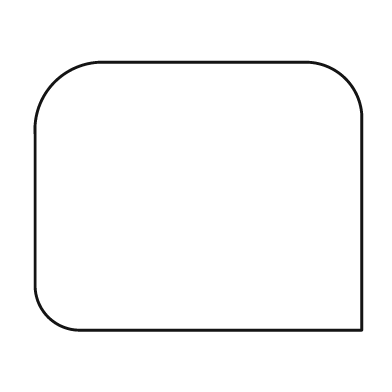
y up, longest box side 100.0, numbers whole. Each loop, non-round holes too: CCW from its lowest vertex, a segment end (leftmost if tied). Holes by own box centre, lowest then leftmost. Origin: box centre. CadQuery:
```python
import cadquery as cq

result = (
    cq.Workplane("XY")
    .moveTo(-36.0, -41.0)
    .lineTo(50.0, -41.0)
    .lineTo(50.0, 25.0)
    .threePointArc((45.0, 36.0), (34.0, 41.0))
    .lineTo(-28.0, 41.0)
    .threePointArc((-44.0, 35.0), (-50.0, 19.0))
    .lineTo(-50.0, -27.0)
    .threePointArc((-46.0, -37.0), (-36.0, -41.0))
    .close()
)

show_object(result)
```